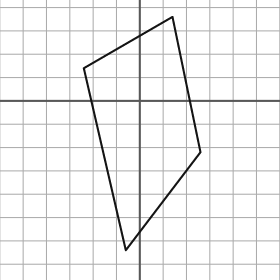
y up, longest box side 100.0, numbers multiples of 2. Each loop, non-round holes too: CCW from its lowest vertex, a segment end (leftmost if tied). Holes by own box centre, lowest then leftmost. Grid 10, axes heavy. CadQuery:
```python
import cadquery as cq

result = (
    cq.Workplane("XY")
    .moveTo(-6.0, -64.0)
    .lineTo(26.0, -22.0)
    .lineTo(14.0, 36.0)
    .lineTo(-24.0, 14.0)
    .close()
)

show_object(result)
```